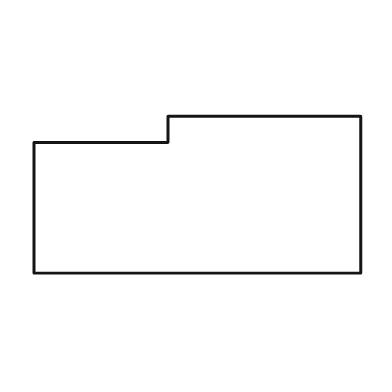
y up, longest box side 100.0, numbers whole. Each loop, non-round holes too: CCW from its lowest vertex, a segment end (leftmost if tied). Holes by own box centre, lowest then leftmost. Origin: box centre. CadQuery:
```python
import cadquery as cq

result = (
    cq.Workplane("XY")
    .moveTo(-50.0, -24.0)
    .lineTo(50.0, -24.0)
    .lineTo(50.0, 24.0)
    .lineTo(-9.0, 24.0)
    .lineTo(-9.0, 16.0)
    .lineTo(-50.0, 16.0)
    .close()
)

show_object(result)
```